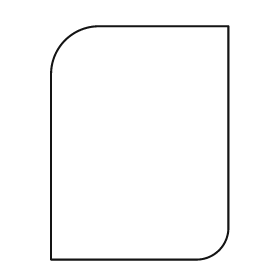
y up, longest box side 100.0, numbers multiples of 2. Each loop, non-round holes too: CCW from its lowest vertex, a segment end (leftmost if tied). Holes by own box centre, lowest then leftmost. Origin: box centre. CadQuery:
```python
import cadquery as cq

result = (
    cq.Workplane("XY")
    .moveTo(-38.0, -50.0)
    .lineTo(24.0, -50.0)
    .threePointArc((34.0, -46.0), (38.0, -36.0))
    .lineTo(38.0, 50.0)
    .lineTo(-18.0, 50.0)
    .threePointArc((-32.0, 44.0), (-38.0, 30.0))
    .close()
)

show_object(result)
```